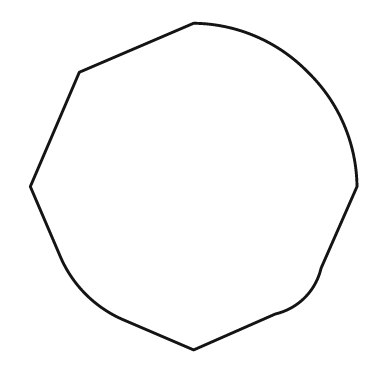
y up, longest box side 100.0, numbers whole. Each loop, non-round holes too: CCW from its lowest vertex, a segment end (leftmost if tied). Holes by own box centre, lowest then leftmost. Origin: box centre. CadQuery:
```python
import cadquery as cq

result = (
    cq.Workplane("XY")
    .moveTo(0.0, -50.0)
    .lineTo(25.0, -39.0)
    .threePointArc((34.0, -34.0), (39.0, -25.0))
    .lineTo(50.0, 0.0)
    .threePointArc((46.0, 19.0), (35.0, 35.0))
    .threePointArc((19.0, 46.0), (0.0, 50.0))
    .lineTo(-35.0, 35.0)
    .lineTo(-50.0, 0.0)
    .lineTo(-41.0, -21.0)
    .threePointArc((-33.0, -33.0), (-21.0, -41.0))
    .close()
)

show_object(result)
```